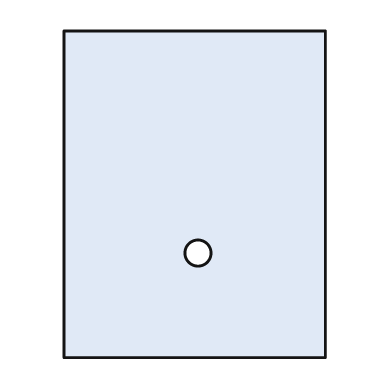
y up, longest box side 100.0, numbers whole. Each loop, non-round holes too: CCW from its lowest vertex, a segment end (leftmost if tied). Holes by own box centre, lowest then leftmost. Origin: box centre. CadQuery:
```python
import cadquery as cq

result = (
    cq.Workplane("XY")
    .moveTo(-40.0, -50.0)
    .lineTo(40.0, -50.0)
    .lineTo(40.0, 50.0)
    .lineTo(-40.0, 50.0)
    .close()
    .moveTo(1.0, -18.0)
    .circle(4.0)
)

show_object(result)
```